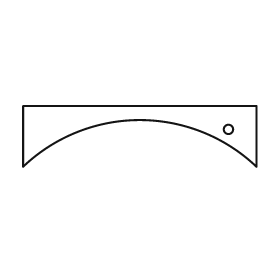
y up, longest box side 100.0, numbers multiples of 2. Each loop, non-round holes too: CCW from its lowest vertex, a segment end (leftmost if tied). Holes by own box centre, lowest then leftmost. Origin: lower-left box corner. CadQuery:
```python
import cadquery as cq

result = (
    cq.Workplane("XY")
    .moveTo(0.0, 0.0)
    .threePointArc((50.0, 20.0), (100.0, 0.0))
    .lineTo(100.0, 26.0)
    .lineTo(0.0, 26.0)
    .close()
    .moveTo(88.0, 16.0)
    .circle(2.0)
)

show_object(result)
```